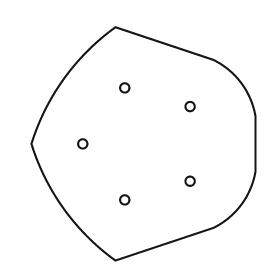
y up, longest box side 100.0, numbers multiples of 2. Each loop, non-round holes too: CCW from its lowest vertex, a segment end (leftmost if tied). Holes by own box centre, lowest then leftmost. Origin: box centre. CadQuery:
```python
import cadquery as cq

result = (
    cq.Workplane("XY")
    .moveTo(-12.0, -50.0)
    .lineTo(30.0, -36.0)
    .threePointArc((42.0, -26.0), (48.0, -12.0))
    .lineTo(48.0, 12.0)
    .threePointArc((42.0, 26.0), (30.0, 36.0))
    .lineTo(-12.0, 50.0)
    .threePointArc((-34.0, 28.0), (-48.0, 0.0))
    .threePointArc((-34.0, -28.0), (-12.0, -50.0))
    .close()
    .moveTo(-8.0, -24.0)
    .circle(2.0)
    .moveTo(20.0, -16.0)
    .circle(2.0)
    .moveTo(-26.0, 0.0)
    .circle(2.0)
    .moveTo(20.0, 16.0)
    .circle(2.0)
    .moveTo(-8.0, 24.0)
    .circle(2.0)
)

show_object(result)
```